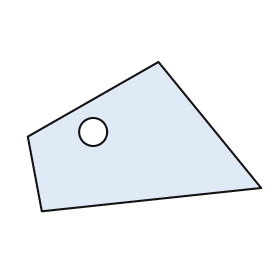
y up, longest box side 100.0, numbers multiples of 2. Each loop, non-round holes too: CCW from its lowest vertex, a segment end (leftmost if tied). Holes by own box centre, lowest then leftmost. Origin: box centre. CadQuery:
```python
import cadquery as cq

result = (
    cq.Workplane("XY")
    .moveTo(-44.0, -32.0)
    .lineTo(50.0, -22.0)
    .lineTo(6.0, 32.0)
    .lineTo(-50.0, 0.0)
    .close()
    .moveTo(-22.0, 2.0)
    .circle(6.0)
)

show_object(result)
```